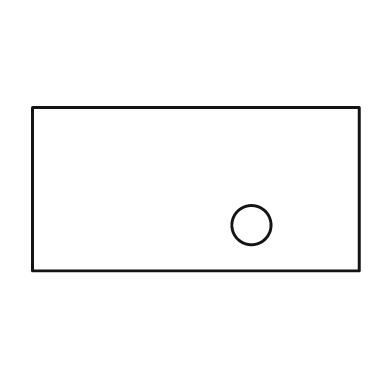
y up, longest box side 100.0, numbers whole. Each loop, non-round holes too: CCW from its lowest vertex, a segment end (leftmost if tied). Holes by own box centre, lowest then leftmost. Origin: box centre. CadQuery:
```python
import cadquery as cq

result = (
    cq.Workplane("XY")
    .moveTo(-50.0, -25.0)
    .lineTo(50.0, -25.0)
    .lineTo(50.0, 25.0)
    .lineTo(-50.0, 25.0)
    .close()
    .moveTo(17.0, -11.0)
    .circle(6.0)
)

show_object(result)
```